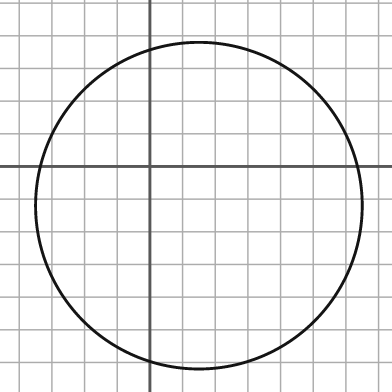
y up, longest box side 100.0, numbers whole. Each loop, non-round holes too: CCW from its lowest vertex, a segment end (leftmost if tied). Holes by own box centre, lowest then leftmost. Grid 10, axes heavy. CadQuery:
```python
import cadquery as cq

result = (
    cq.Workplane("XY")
    .moveTo(15.0, -12.0)
    .circle(50.0)
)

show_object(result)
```